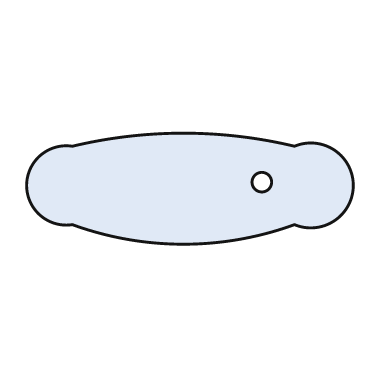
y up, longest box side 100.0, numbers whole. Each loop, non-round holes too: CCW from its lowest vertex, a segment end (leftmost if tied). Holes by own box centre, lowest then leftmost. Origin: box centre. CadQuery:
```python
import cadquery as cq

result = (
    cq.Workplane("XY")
    .moveTo(-36.0, -11.0)
    .threePointArc((-2.0, -17.0), (32.0, -11.0))
    .threePointArc((50.0, 1.0), (32.0, 13.0))
    .threePointArc((-2.0, 17.0), (-36.0, 13.0))
    .threePointArc((-50.0, 1.0), (-36.0, -11.0))
    .close()
    .moveTo(22.0, 2.0)
    .circle(3.0)
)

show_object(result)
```